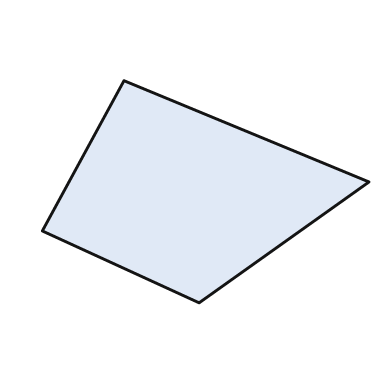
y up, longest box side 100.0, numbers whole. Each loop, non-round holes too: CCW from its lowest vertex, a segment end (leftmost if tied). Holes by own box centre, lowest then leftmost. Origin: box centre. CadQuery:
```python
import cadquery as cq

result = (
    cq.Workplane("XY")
    .moveTo(-2.0, -34.0)
    .lineTo(50.0, 3.0)
    .lineTo(-25.0, 34.0)
    .lineTo(-50.0, -12.0)
    .close()
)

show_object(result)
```